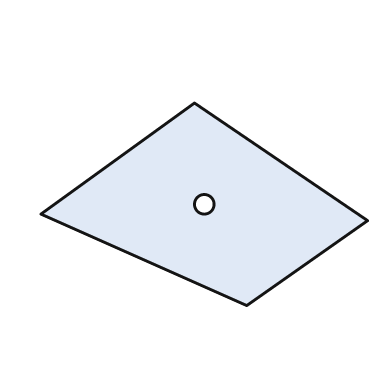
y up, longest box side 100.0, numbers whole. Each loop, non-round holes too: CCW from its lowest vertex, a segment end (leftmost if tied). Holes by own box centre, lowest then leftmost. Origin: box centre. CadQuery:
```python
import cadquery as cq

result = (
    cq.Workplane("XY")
    .moveTo(13.0, -31.0)
    .lineTo(50.0, -5.0)
    .lineTo(-3.0, 31.0)
    .lineTo(-50.0, -3.0)
    .close()
    .moveTo(0.0, 0.0)
    .circle(3.0)
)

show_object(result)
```